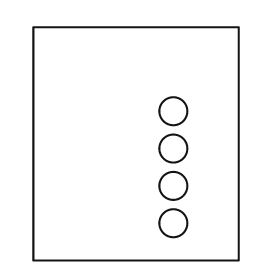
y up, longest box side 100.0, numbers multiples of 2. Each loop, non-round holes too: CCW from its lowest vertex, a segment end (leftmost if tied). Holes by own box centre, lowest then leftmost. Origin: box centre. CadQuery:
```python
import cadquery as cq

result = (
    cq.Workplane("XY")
    .moveTo(-44.0, -50.0)
    .lineTo(44.0, -50.0)
    .lineTo(44.0, 50.0)
    .lineTo(-44.0, 50.0)
    .close()
    .moveTo(16.0, -34.0)
    .circle(6.0)
    .moveTo(16.0, -18.0)
    .circle(6.0)
    .moveTo(16.0, -2.0)
    .circle(6.0)
    .moveTo(16.0, 14.0)
    .circle(6.0)
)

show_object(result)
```